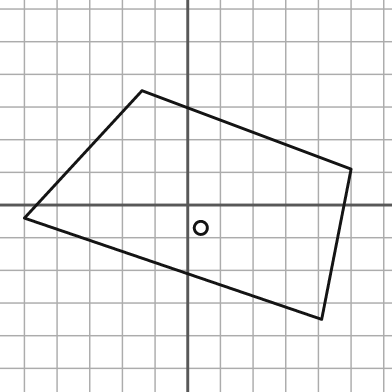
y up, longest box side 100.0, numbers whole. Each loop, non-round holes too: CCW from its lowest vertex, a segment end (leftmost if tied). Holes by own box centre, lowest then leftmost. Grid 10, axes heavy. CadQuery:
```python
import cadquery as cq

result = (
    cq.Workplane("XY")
    .moveTo(41.0, -35.0)
    .lineTo(50.0, 11.0)
    .lineTo(-14.0, 35.0)
    .lineTo(-50.0, -4.0)
    .close()
    .moveTo(4.0, -7.0)
    .circle(2.0)
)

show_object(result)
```